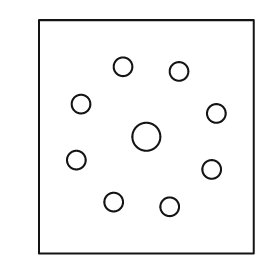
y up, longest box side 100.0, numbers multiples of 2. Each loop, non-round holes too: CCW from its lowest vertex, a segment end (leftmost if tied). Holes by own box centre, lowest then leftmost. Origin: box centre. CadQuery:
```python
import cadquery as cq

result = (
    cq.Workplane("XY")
    .moveTo(-46.0, -50.0)
    .lineTo(46.0, -50.0)
    .lineTo(46.0, 50.0)
    .lineTo(-46.0, 50.0)
    .close()
    .moveTo(10.0, -30.0)
    .circle(4.0)
    .moveTo(-14.0, -28.0)
    .circle(4.0)
    .moveTo(28.0, -14.0)
    .circle(4.0)
    .moveTo(-30.0, -10.0)
    .circle(4.0)
    .moveTo(0.0, 0.0)
    .circle(6.0)
    .moveTo(30.0, 10.0)
    .circle(4.0)
    .moveTo(-28.0, 14.0)
    .circle(4.0)
    .moveTo(14.0, 28.0)
    .circle(4.0)
    .moveTo(-10.0, 30.0)
    .circle(4.0)
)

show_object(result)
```